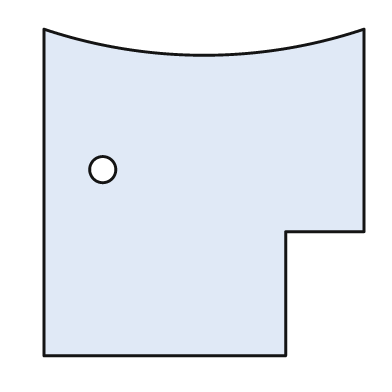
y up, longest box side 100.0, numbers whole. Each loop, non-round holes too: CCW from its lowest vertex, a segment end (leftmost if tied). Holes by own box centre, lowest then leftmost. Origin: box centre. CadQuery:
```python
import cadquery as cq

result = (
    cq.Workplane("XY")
    .moveTo(-49.0, -50.0)
    .lineTo(25.0, -50.0)
    .lineTo(25.0, -12.0)
    .lineTo(49.0, -12.0)
    .lineTo(49.0, 50.0)
    .threePointArc((0.0, 42.0), (-49.0, 50.0))
    .close()
    .moveTo(-31.0, 7.0)
    .circle(4.0)
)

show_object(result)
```